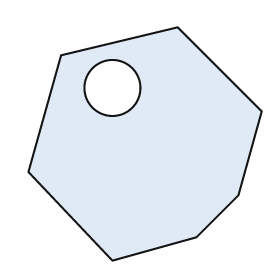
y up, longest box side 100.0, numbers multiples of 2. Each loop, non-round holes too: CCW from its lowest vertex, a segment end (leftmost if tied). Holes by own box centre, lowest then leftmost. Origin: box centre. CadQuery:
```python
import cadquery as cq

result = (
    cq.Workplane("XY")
    .moveTo(-14.0, -50.0)
    .lineTo(22.0, -40.0)
    .lineTo(40.0, -22.0)
    .lineTo(50.0, 14.0)
    .lineTo(14.0, 50.0)
    .lineTo(-36.0, 38.0)
    .lineTo(-50.0, -12.0)
    .close()
    .moveTo(-14.0, 24.0)
    .circle(12.0)
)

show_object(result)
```